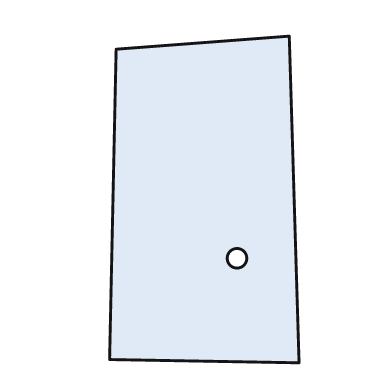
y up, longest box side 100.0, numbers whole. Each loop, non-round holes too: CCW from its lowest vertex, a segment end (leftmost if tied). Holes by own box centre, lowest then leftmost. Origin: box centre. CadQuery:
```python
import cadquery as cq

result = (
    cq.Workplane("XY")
    .moveTo(29.0, -50.0)
    .lineTo(26.0, 50.0)
    .lineTo(-27.0, 46.0)
    .lineTo(-29.0, -49.0)
    .close()
    .moveTo(10.0, -18.0)
    .circle(3.0)
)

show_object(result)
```